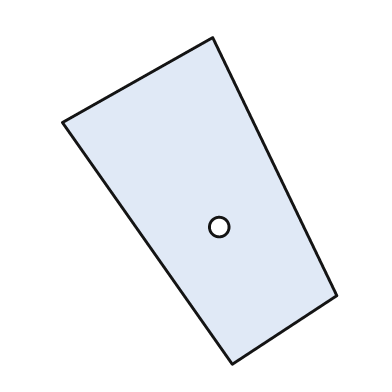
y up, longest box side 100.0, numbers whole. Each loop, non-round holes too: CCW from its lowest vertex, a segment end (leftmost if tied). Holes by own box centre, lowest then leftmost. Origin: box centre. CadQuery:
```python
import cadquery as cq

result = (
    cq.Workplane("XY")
    .moveTo(10.0, -50.0)
    .lineTo(42.0, -29.0)
    .lineTo(4.0, 50.0)
    .lineTo(-42.0, 24.0)
    .close()
    .moveTo(6.0, -8.0)
    .circle(3.0)
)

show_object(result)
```